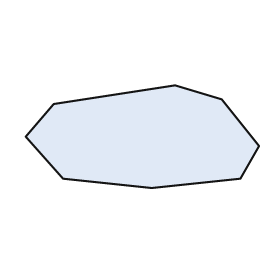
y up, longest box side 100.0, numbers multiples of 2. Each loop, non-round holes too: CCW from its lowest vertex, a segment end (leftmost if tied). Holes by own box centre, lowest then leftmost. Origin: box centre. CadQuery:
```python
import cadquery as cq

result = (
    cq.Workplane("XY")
    .moveTo(4.0, -22.0)
    .lineTo(42.0, -18.0)
    .lineTo(50.0, -4.0)
    .lineTo(34.0, 16.0)
    .lineTo(14.0, 22.0)
    .lineTo(-38.0, 14.0)
    .lineTo(-50.0, 0.0)
    .lineTo(-34.0, -18.0)
    .close()
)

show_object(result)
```